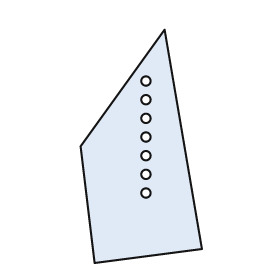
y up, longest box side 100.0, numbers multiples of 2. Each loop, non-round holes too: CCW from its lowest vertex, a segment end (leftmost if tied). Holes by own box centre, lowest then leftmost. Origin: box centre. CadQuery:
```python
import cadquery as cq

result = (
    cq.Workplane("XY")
    .moveTo(-20.0, -50.0)
    .lineTo(26.0, -44.0)
    .lineTo(10.0, 50.0)
    .lineTo(-26.0, 0.0)
    .close()
    .moveTo(2.0, -20.0)
    .circle(2.0)
    .moveTo(2.0, -12.0)
    .circle(2.0)
    .moveTo(2.0, -4.0)
    .circle(2.0)
    .moveTo(2.0, 4.0)
    .circle(2.0)
    .moveTo(2.0, 12.0)
    .circle(2.0)
    .moveTo(2.0, 20.0)
    .circle(2.0)
    .moveTo(2.0, 28.0)
    .circle(2.0)
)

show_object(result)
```